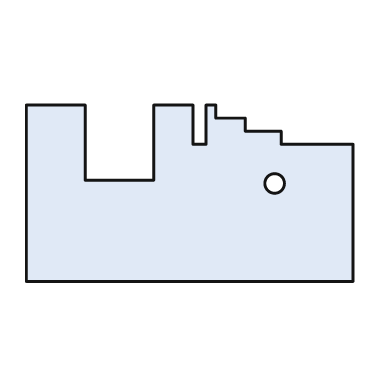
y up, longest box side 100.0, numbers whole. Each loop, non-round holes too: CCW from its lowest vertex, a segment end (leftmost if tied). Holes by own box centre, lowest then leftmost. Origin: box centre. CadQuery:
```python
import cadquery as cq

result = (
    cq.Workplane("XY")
    .moveTo(-50.0, -27.0)
    .lineTo(50.0, -27.0)
    .lineTo(50.0, 15.0)
    .lineTo(28.0, 15.0)
    .lineTo(28.0, 19.0)
    .lineTo(17.0, 19.0)
    .lineTo(17.0, 23.0)
    .lineTo(8.0, 23.0)
    .lineTo(8.0, 27.0)
    .lineTo(5.0, 27.0)
    .lineTo(5.0, 15.0)
    .lineTo(1.0, 15.0)
    .lineTo(1.0, 27.0)
    .lineTo(-11.0, 27.0)
    .lineTo(-11.0, 4.0)
    .lineTo(-32.0, 4.0)
    .lineTo(-32.0, 27.0)
    .lineTo(-50.0, 27.0)
    .close()
    .moveTo(26.0, 3.0)
    .circle(3.0)
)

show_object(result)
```